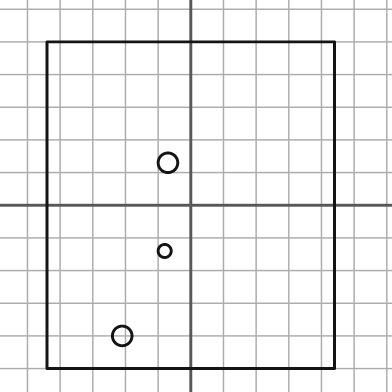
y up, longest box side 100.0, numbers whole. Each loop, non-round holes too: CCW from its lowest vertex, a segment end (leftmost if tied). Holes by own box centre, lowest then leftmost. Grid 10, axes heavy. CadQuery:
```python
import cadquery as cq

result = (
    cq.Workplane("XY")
    .moveTo(-44.0, -50.0)
    .lineTo(44.0, -50.0)
    .lineTo(44.0, 50.0)
    .lineTo(-44.0, 50.0)
    .close()
    .moveTo(-21.0, -40.0)
    .circle(3.0)
    .moveTo(-8.0, -14.0)
    .circle(2.0)
    .moveTo(-7.0, 13.0)
    .circle(3.0)
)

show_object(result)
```